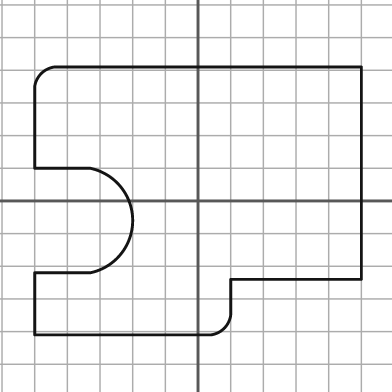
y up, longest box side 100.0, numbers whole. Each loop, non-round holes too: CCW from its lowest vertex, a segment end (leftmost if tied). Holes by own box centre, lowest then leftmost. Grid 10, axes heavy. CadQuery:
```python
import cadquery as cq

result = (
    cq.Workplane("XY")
    .moveTo(-50.0, -41.0)
    .lineTo(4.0, -41.0)
    .threePointArc((8.0, -39.0), (10.0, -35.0))
    .lineTo(10.0, -24.0)
    .lineTo(50.0, -24.0)
    .lineTo(50.0, 41.0)
    .lineTo(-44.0, 41.0)
    .threePointArc((-48.0, 39.0), (-50.0, 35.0))
    .lineTo(-50.0, 10.0)
    .lineTo(-33.0, 10.0)
    .threePointArc((-20.0, -6.0), (-33.0, -22.0))
    .lineTo(-50.0, -22.0)
    .close()
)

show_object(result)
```